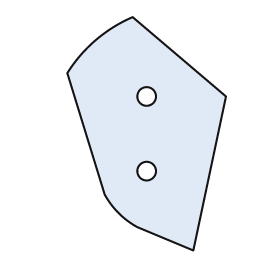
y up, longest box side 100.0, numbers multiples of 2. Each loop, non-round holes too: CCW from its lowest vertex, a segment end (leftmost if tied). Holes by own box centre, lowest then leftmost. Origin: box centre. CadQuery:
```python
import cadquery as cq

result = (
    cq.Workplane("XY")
    .moveTo(20.0, -50.0)
    .lineTo(34.0, 16.0)
    .lineTo(-6.0, 50.0)
    .threePointArc((-22.0, 40.0), (-34.0, 26.0))
    .lineTo(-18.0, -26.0)
    .threePointArc((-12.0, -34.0), (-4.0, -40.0))
    .close()
    .moveTo(0.0, -16.0)
    .circle(4.0)
    .moveTo(0.0, 16.0)
    .circle(4.0)
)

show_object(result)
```